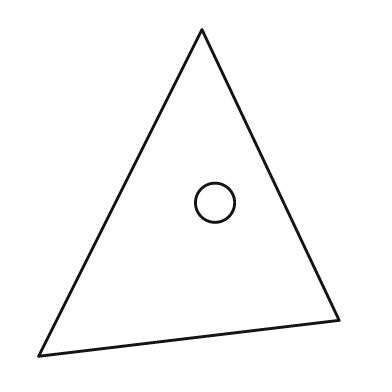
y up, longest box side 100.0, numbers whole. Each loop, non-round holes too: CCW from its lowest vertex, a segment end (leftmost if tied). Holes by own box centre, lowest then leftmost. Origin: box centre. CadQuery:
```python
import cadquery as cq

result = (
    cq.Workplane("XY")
    .moveTo(-46.0, -50.0)
    .lineTo(46.0, -39.0)
    .lineTo(4.0, 50.0)
    .close()
    .moveTo(8.0, -3.0)
    .circle(6.0)
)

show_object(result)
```